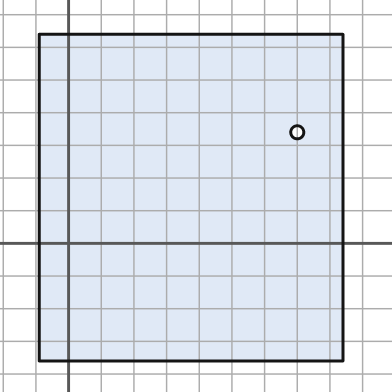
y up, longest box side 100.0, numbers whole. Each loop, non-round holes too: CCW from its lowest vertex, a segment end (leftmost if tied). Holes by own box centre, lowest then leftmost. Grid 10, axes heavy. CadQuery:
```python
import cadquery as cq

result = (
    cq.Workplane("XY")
    .moveTo(-9.0, -36.0)
    .lineTo(84.0, -36.0)
    .lineTo(84.0, 64.0)
    .lineTo(-9.0, 64.0)
    .close()
    .moveTo(70.0, 34.0)
    .circle(2.0)
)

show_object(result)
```